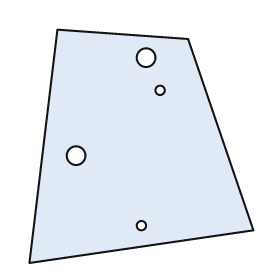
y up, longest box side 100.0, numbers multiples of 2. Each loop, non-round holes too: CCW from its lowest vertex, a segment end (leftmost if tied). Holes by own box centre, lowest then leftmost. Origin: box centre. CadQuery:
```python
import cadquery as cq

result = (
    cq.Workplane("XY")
    .moveTo(-48.0, -50.0)
    .lineTo(48.0, -36.0)
    .lineTo(20.0, 46.0)
    .lineTo(-36.0, 50.0)
    .close()
    .moveTo(0.0, -34.0)
    .circle(2.0)
    .moveTo(-28.0, -4.0)
    .circle(4.0)
    .moveTo(8.0, 24.0)
    .circle(2.0)
    .moveTo(2.0, 38.0)
    .circle(4.0)
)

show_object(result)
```